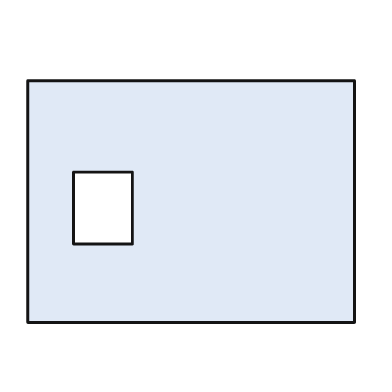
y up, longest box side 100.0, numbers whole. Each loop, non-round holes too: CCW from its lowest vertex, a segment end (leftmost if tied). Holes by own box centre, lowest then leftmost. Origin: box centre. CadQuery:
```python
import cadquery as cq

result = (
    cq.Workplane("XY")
    .moveTo(-50.0, -37.0)
    .lineTo(50.0, -37.0)
    .lineTo(50.0, 37.0)
    .lineTo(-50.0, 37.0)
    .close()
    .moveTo(-36.0, -13.0)
    .lineTo(-18.0, -13.0)
    .lineTo(-18.0, 9.0)
    .lineTo(-36.0, 9.0)
    .close()
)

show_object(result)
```